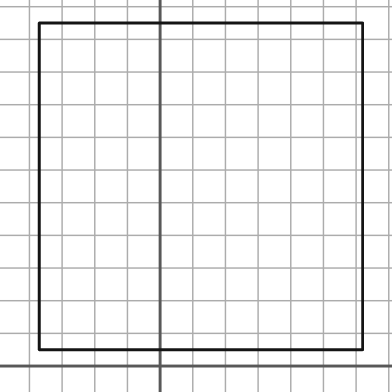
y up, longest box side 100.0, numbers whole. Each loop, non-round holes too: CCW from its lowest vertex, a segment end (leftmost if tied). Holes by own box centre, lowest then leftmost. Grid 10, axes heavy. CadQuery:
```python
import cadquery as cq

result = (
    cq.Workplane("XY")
    .moveTo(-37.0, 5.0)
    .lineTo(62.0, 5.0)
    .lineTo(62.0, 105.0)
    .lineTo(-37.0, 105.0)
    .close()
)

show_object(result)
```